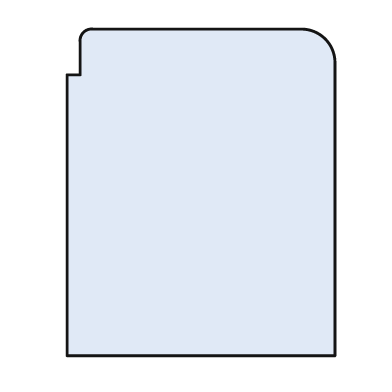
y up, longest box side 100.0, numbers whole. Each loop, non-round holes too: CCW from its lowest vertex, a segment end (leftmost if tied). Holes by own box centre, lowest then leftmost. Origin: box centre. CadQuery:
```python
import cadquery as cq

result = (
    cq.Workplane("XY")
    .moveTo(-41.0, -50.0)
    .lineTo(41.0, -50.0)
    .lineTo(41.0, 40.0)
    .threePointArc((38.0, 47.0), (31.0, 50.0))
    .lineTo(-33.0, 50.0)
    .threePointArc((-36.0, 49.0), (-37.0, 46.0))
    .lineTo(-37.0, 36.0)
    .lineTo(-41.0, 36.0)
    .close()
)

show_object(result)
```